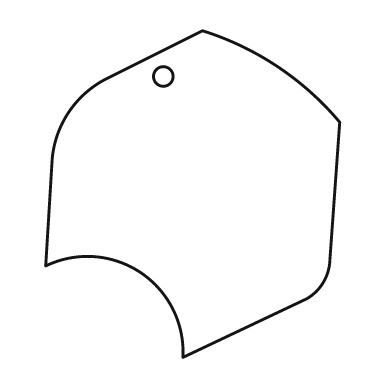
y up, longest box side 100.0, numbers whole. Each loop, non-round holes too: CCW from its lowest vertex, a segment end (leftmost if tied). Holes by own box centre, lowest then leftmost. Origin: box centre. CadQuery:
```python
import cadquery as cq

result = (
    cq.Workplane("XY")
    .moveTo(-3.0, -50.0)
    .lineTo(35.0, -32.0)
    .threePointArc((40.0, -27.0), (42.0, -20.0))
    .lineTo(45.0, 22.0)
    .threePointArc((26.0, 39.0), (3.0, 50.0))
    .lineTo(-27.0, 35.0)
    .threePointArc((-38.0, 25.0), (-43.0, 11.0))
    .lineTo(-45.0, -22.0)
    .threePointArc((-16.0, -24.0), (-3.0, -50.0))
    .close()
    .moveTo(-9.0, 36.0)
    .circle(3.0)
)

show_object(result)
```